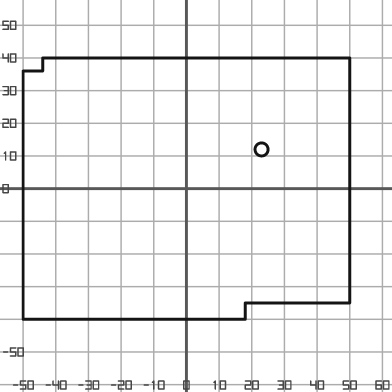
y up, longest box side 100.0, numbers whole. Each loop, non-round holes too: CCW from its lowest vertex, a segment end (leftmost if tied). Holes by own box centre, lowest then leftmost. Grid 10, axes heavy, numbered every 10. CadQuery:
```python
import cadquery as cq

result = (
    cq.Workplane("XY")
    .moveTo(-50.0, -40.0)
    .lineTo(18.0, -40.0)
    .lineTo(18.0, -35.0)
    .lineTo(50.0, -35.0)
    .lineTo(50.0, 40.0)
    .lineTo(-44.0, 40.0)
    .lineTo(-44.0, 36.0)
    .lineTo(-50.0, 36.0)
    .close()
    .moveTo(23.0, 12.0)
    .circle(2.0)
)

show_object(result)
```